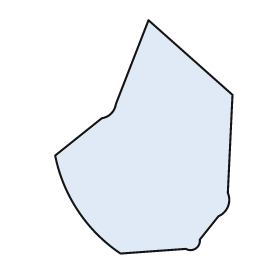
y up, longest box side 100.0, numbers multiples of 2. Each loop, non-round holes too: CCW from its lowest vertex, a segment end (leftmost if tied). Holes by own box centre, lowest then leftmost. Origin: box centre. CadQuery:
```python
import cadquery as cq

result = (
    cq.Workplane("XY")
    .moveTo(-10.0, -50.0)
    .lineTo(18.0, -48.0)
    .threePointArc((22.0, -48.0), (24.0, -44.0))
    .lineTo(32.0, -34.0)
    .threePointArc((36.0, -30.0), (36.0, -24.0))
    .lineTo(38.0, 18.0)
    .lineTo(2.0, 50.0)
    .lineTo(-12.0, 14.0)
    .threePointArc((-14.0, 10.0), (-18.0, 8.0))
    .lineTo(-38.0, -8.0)
    .threePointArc((-28.0, -32.0), (-10.0, -50.0))
    .close()
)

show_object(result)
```